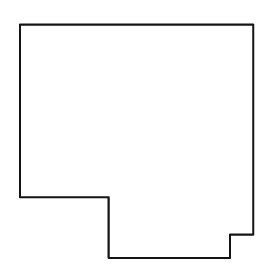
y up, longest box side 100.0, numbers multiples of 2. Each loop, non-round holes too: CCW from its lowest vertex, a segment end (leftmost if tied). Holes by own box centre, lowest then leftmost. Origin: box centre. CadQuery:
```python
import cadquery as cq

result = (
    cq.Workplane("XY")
    .moveTo(-12.0, -50.0)
    .lineTo(40.0, -50.0)
    .lineTo(40.0, -40.0)
    .lineTo(50.0, -40.0)
    .lineTo(50.0, 50.0)
    .lineTo(-50.0, 50.0)
    .lineTo(-50.0, -24.0)
    .lineTo(-12.0, -24.0)
    .close()
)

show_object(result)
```